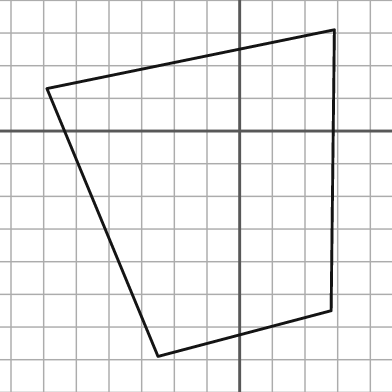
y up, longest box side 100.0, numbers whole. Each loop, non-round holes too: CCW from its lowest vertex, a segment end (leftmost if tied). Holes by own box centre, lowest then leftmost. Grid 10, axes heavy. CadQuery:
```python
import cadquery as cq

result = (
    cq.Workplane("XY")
    .moveTo(-25.0, -69.0)
    .lineTo(28.0, -55.0)
    .lineTo(29.0, 31.0)
    .lineTo(-59.0, 13.0)
    .close()
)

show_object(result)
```